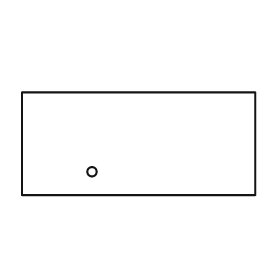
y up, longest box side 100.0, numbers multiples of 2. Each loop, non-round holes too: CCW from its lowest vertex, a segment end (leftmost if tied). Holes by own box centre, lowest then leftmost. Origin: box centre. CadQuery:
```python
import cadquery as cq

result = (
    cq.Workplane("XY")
    .moveTo(-50.0, -22.0)
    .lineTo(50.0, -22.0)
    .lineTo(50.0, 22.0)
    .lineTo(-50.0, 22.0)
    .close()
    .moveTo(-20.0, -12.0)
    .circle(2.0)
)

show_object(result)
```